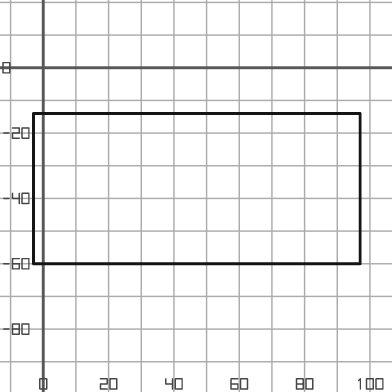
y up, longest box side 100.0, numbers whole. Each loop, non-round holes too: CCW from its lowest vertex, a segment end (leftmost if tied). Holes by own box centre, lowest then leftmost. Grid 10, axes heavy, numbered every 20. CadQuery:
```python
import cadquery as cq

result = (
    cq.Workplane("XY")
    .moveTo(-3.0, -60.0)
    .lineTo(97.0, -60.0)
    .lineTo(97.0, -14.0)
    .lineTo(-3.0, -14.0)
    .close()
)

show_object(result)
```